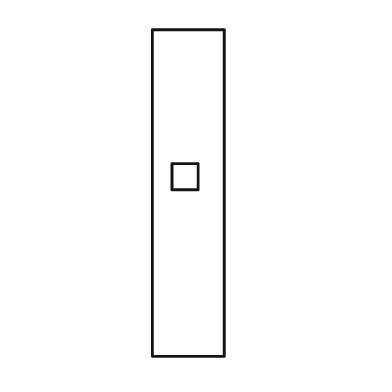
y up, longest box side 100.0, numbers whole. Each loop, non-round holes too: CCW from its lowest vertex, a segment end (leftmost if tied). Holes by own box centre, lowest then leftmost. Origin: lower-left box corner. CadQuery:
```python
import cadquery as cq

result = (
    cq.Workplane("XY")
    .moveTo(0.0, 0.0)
    .lineTo(22.0, 0.0)
    .lineTo(22.0, 100.0)
    .lineTo(0.0, 100.0)
    .close()
    .moveTo(6.0, 51.0)
    .lineTo(14.0, 51.0)
    .lineTo(14.0, 59.0)
    .lineTo(6.0, 59.0)
    .close()
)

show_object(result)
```